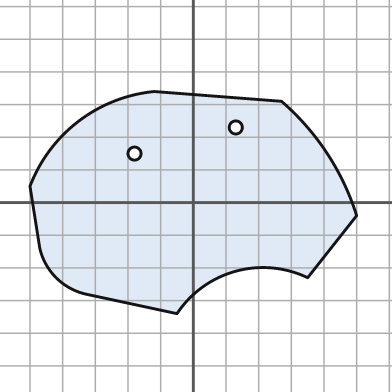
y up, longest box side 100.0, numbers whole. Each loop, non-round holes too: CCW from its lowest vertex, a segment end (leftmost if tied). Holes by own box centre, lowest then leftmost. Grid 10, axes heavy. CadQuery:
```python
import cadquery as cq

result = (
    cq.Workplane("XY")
    .moveTo(-5.0, -34.0)
    .threePointArc((13.0, -21.0), (35.0, -23.0))
    .lineTo(50.0, -4.0)
    .threePointArc((41.0, 15.0), (27.0, 31.0))
    .lineTo(-12.0, 34.0)
    .threePointArc((-35.0, 25.0), (-50.0, 5.0))
    .lineTo(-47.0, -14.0)
    .threePointArc((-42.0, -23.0), (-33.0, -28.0))
    .close()
    .moveTo(-18.0, 15.0)
    .circle(2.0)
    .moveTo(13.0, 23.0)
    .circle(2.0)
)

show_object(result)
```